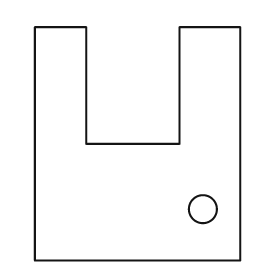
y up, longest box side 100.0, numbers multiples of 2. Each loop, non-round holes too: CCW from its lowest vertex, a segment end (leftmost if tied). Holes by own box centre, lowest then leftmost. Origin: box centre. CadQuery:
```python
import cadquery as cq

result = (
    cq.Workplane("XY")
    .moveTo(-44.0, -50.0)
    .lineTo(44.0, -50.0)
    .lineTo(44.0, 50.0)
    .lineTo(18.0, 50.0)
    .lineTo(18.0, 0.0)
    .lineTo(-22.0, 0.0)
    .lineTo(-22.0, 50.0)
    .lineTo(-44.0, 50.0)
    .close()
    .moveTo(28.0, -28.0)
    .circle(6.0)
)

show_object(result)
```